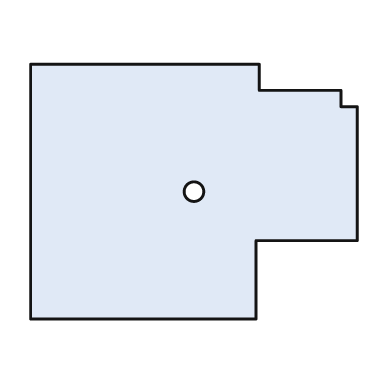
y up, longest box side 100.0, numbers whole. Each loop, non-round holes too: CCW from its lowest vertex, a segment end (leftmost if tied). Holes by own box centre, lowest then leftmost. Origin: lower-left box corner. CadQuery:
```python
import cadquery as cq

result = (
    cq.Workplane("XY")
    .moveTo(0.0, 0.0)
    .lineTo(69.0, 0.0)
    .lineTo(69.0, 24.0)
    .lineTo(100.0, 24.0)
    .lineTo(100.0, 65.0)
    .lineTo(95.0, 65.0)
    .lineTo(95.0, 70.0)
    .lineTo(70.0, 70.0)
    .lineTo(70.0, 78.0)
    .lineTo(0.0, 78.0)
    .close()
    .moveTo(50.0, 39.0)
    .circle(3.0)
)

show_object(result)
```